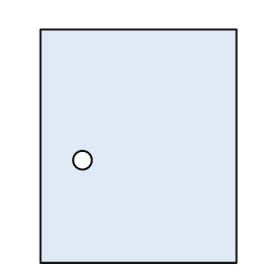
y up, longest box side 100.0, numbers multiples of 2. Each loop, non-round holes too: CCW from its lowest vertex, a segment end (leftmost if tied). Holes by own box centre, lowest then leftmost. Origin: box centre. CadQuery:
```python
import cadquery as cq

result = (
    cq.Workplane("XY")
    .moveTo(-42.0, -50.0)
    .lineTo(42.0, -50.0)
    .lineTo(42.0, 50.0)
    .lineTo(-42.0, 50.0)
    .close()
    .moveTo(-24.0, -6.0)
    .circle(4.0)
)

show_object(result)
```